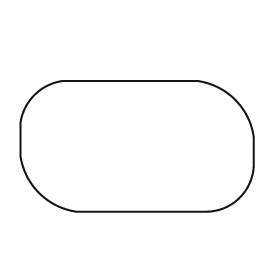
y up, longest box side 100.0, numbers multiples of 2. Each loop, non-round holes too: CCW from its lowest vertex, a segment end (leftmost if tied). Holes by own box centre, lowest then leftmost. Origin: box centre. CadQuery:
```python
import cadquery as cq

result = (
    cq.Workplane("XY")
    .moveTo(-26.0, -28.0)
    .lineTo(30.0, -28.0)
    .threePointArc((44.0, -22.0), (50.0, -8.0))
    .lineTo(50.0, 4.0)
    .threePointArc((42.0, 20.0), (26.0, 28.0))
    .lineTo(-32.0, 28.0)
    .threePointArc((-44.0, 22.0), (-50.0, 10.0))
    .lineTo(-50.0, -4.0)
    .threePointArc((-42.0, -20.0), (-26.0, -28.0))
    .close()
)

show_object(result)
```